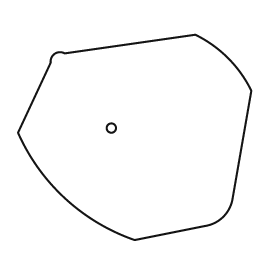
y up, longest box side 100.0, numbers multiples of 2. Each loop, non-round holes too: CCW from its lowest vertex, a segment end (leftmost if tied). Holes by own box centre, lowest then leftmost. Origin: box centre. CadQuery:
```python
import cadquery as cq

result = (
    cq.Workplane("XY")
    .moveTo(0.0, -44.0)
    .lineTo(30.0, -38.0)
    .threePointArc((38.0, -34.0), (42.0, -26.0))
    .lineTo(50.0, 20.0)
    .threePointArc((40.0, 34.0), (26.0, 44.0))
    .lineTo(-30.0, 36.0)
    .threePointArc((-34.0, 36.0), (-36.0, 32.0))
    .lineTo(-50.0, 2.0)
    .threePointArc((-30.0, -26.0), (0.0, -44.0))
    .close()
    .moveTo(-10.0, 4.0)
    .circle(2.0)
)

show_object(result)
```